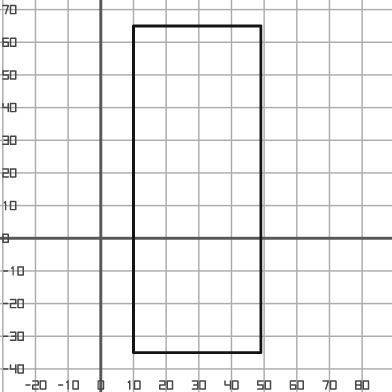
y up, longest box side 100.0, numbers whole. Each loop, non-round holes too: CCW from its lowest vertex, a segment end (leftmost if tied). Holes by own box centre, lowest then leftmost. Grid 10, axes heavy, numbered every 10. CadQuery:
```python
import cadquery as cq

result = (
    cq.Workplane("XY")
    .moveTo(10.0, -35.0)
    .lineTo(49.0, -35.0)
    .lineTo(49.0, 65.0)
    .lineTo(10.0, 65.0)
    .close()
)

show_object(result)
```